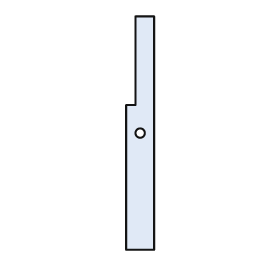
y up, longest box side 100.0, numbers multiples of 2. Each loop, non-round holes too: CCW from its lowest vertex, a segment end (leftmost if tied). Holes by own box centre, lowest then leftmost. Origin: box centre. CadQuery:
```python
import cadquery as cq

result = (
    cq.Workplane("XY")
    .moveTo(-6.0, -50.0)
    .lineTo(6.0, -50.0)
    .lineTo(6.0, 50.0)
    .lineTo(-2.0, 50.0)
    .lineTo(-2.0, 12.0)
    .lineTo(-6.0, 12.0)
    .close()
    .moveTo(0.0, 0.0)
    .circle(2.0)
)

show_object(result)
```